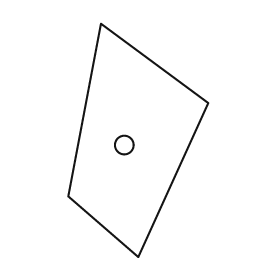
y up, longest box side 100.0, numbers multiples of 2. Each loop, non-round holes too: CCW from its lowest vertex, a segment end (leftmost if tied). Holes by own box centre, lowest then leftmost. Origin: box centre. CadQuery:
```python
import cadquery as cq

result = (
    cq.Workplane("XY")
    .moveTo(0.0, -50.0)
    .lineTo(30.0, 16.0)
    .lineTo(-16.0, 50.0)
    .lineTo(-30.0, -24.0)
    .close()
    .moveTo(-6.0, -2.0)
    .circle(4.0)
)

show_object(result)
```